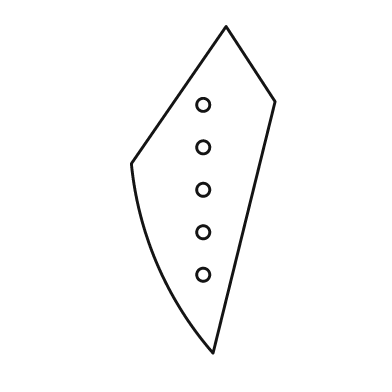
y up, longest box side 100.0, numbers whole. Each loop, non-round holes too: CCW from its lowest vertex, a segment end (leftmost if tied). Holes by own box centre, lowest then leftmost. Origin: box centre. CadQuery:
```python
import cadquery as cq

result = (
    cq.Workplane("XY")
    .moveTo(3.0, -50.0)
    .lineTo(22.0, 27.0)
    .lineTo(7.0, 50.0)
    .lineTo(-22.0, 8.0)
    .threePointArc((-14.0, -23.0), (3.0, -50.0))
    .close()
    .moveTo(0.0, -26.0)
    .circle(2.0)
    .moveTo(0.0, -13.0)
    .circle(2.0)
    .moveTo(0.0, 0.0)
    .circle(2.0)
    .moveTo(0.0, 13.0)
    .circle(2.0)
    .moveTo(0.0, 26.0)
    .circle(2.0)
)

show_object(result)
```